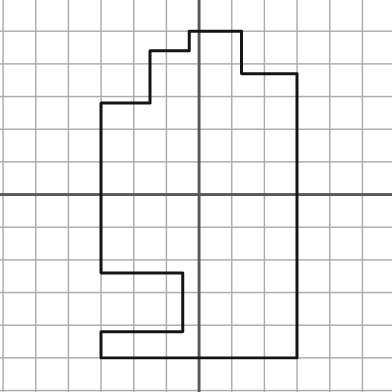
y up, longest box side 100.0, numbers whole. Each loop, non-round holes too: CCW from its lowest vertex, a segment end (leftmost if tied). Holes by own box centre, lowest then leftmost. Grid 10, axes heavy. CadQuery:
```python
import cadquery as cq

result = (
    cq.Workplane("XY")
    .moveTo(-30.0, -50.0)
    .lineTo(30.0, -50.0)
    .lineTo(30.0, 37.0)
    .lineTo(13.0, 37.0)
    .lineTo(13.0, 50.0)
    .lineTo(-3.0, 50.0)
    .lineTo(-3.0, 44.0)
    .lineTo(-15.0, 44.0)
    .lineTo(-15.0, 28.0)
    .lineTo(-30.0, 28.0)
    .lineTo(-30.0, -24.0)
    .lineTo(-5.0, -24.0)
    .lineTo(-5.0, -42.0)
    .lineTo(-30.0, -42.0)
    .close()
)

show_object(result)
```